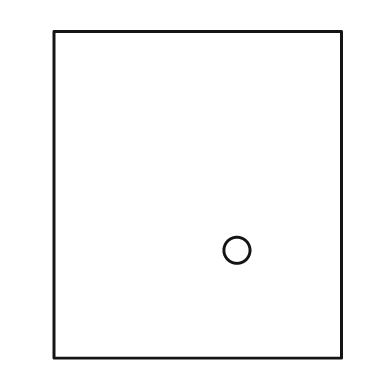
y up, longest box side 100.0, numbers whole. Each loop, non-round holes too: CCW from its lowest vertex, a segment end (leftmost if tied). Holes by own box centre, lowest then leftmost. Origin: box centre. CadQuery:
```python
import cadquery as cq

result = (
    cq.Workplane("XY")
    .moveTo(-44.0, -50.0)
    .lineTo(44.0, -50.0)
    .lineTo(44.0, 50.0)
    .lineTo(-44.0, 50.0)
    .close()
    .moveTo(12.0, -17.0)
    .circle(4.0)
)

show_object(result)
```